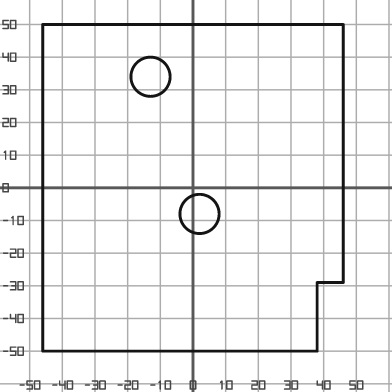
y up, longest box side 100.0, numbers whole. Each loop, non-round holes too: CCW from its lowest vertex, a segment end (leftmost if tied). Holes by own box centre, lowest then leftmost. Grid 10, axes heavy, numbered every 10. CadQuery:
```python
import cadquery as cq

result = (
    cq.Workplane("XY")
    .moveTo(-46.0, -50.0)
    .lineTo(38.0, -50.0)
    .lineTo(38.0, -29.0)
    .lineTo(46.0, -29.0)
    .lineTo(46.0, 50.0)
    .lineTo(-46.0, 50.0)
    .close()
    .moveTo(2.0, -8.0)
    .circle(6.0)
    .moveTo(-13.0, 34.0)
    .circle(6.0)
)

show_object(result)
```